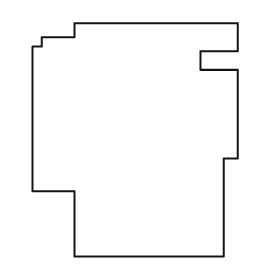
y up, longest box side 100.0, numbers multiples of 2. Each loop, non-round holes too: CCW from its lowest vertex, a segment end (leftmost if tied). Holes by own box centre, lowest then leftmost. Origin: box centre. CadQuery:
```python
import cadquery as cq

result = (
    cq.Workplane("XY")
    .moveTo(-26.0, -50.0)
    .lineTo(38.0, -50.0)
    .lineTo(38.0, -8.0)
    .lineTo(44.0, -8.0)
    .lineTo(44.0, 30.0)
    .lineTo(28.0, 30.0)
    .lineTo(28.0, 38.0)
    .lineTo(44.0, 38.0)
    .lineTo(44.0, 50.0)
    .lineTo(-26.0, 50.0)
    .lineTo(-26.0, 44.0)
    .lineTo(-40.0, 44.0)
    .lineTo(-40.0, 40.0)
    .lineTo(-44.0, 40.0)
    .lineTo(-44.0, -22.0)
    .lineTo(-26.0, -22.0)
    .close()
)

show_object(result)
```